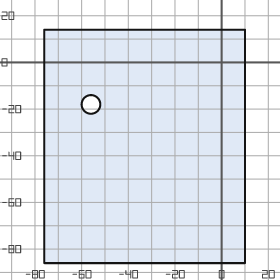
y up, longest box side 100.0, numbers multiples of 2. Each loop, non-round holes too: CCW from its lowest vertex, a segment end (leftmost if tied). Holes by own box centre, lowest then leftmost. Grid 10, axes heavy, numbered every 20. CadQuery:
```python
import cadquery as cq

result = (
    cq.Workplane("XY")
    .moveTo(-76.0, -86.0)
    .lineTo(10.0, -86.0)
    .lineTo(10.0, 14.0)
    .lineTo(-76.0, 14.0)
    .close()
    .moveTo(-56.0, -18.0)
    .circle(4.0)
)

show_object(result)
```